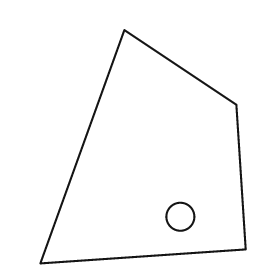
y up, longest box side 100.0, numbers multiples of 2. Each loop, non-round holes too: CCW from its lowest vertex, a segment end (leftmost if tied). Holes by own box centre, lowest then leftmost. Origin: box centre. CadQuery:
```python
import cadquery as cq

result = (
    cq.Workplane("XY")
    .moveTo(-44.0, -50.0)
    .lineTo(44.0, -44.0)
    .lineTo(40.0, 18.0)
    .lineTo(-8.0, 50.0)
    .close()
    .moveTo(16.0, -30.0)
    .circle(6.0)
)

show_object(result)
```